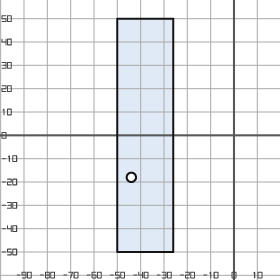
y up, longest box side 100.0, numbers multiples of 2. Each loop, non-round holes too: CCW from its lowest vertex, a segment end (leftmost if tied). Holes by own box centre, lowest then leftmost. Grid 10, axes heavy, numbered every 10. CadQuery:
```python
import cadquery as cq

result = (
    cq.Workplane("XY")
    .moveTo(-50.0, -50.0)
    .lineTo(-26.0, -50.0)
    .lineTo(-26.0, 50.0)
    .lineTo(-50.0, 50.0)
    .close()
    .moveTo(-44.0, -18.0)
    .circle(2.0)
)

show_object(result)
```